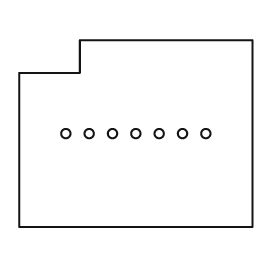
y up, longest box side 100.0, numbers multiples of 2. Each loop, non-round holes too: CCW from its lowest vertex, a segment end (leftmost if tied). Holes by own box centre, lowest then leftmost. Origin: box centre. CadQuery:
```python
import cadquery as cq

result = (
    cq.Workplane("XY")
    .moveTo(-50.0, -40.0)
    .lineTo(50.0, -40.0)
    .lineTo(50.0, 40.0)
    .lineTo(-24.0, 40.0)
    .lineTo(-24.0, 26.0)
    .lineTo(-50.0, 26.0)
    .close()
    .moveTo(-30.0, 0.0)
    .circle(2.0)
    .moveTo(-20.0, 0.0)
    .circle(2.0)
    .moveTo(-10.0, 0.0)
    .circle(2.0)
    .moveTo(0.0, 0.0)
    .circle(2.0)
    .moveTo(10.0, 0.0)
    .circle(2.0)
    .moveTo(20.0, 0.0)
    .circle(2.0)
    .moveTo(30.0, 0.0)
    .circle(2.0)
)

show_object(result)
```